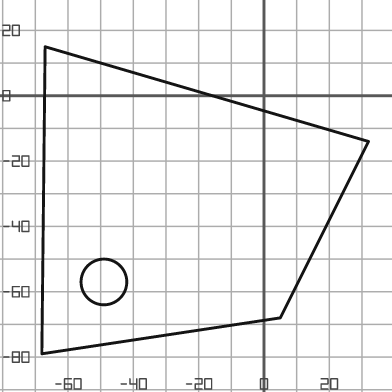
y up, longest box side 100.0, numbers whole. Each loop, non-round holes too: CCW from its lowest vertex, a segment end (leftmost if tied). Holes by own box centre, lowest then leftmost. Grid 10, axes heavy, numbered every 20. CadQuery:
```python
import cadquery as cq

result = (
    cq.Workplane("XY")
    .moveTo(-68.0, -79.0)
    .lineTo(5.0, -68.0)
    .lineTo(32.0, -14.0)
    .lineTo(-67.0, 15.0)
    .close()
    .moveTo(-49.0, -57.0)
    .circle(7.0)
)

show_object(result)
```